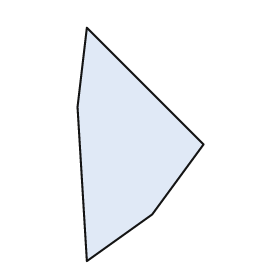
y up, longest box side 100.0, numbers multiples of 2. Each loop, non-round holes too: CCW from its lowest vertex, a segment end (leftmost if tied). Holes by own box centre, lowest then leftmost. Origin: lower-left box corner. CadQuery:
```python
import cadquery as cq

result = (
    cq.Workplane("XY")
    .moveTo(4.0, 0.0)
    .lineTo(32.0, 20.0)
    .lineTo(54.0, 50.0)
    .lineTo(4.0, 100.0)
    .lineTo(0.0, 66.0)
    .close()
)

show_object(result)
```